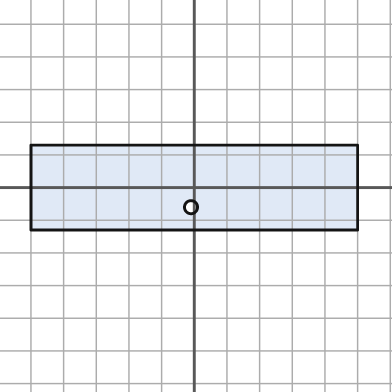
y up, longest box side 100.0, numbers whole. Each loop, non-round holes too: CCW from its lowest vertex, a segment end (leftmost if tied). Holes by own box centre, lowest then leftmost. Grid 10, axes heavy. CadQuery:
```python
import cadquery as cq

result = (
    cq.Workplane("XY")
    .moveTo(-50.0, -13.0)
    .lineTo(50.0, -13.0)
    .lineTo(50.0, 13.0)
    .lineTo(-50.0, 13.0)
    .close()
    .moveTo(-1.0, -6.0)
    .circle(2.0)
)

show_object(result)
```